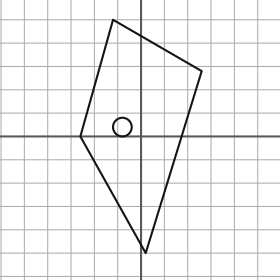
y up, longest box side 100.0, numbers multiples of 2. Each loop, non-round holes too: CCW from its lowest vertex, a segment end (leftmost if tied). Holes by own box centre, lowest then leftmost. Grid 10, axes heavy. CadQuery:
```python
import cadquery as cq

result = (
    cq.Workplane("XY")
    .moveTo(2.0, -50.0)
    .lineTo(26.0, 28.0)
    .lineTo(-12.0, 50.0)
    .lineTo(-26.0, 0.0)
    .close()
    .moveTo(-8.0, 4.0)
    .circle(4.0)
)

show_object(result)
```